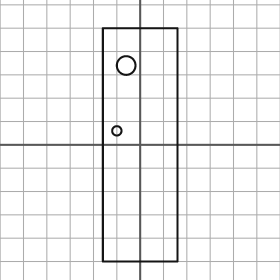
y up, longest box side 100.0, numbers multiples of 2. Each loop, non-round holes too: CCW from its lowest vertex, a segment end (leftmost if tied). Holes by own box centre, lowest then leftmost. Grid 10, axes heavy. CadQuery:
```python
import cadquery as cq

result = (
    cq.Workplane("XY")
    .moveTo(-16.0, -50.0)
    .lineTo(16.0, -50.0)
    .lineTo(16.0, 50.0)
    .lineTo(-16.0, 50.0)
    .close()
    .moveTo(-10.0, 6.0)
    .circle(2.0)
    .moveTo(-6.0, 34.0)
    .circle(4.0)
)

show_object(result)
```